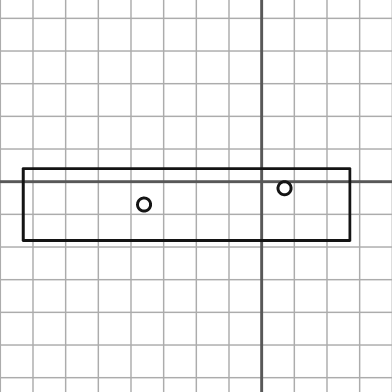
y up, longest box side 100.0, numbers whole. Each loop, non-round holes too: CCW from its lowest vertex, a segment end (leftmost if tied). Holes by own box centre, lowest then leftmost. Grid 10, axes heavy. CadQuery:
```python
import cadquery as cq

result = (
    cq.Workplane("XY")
    .moveTo(-73.0, -18.0)
    .lineTo(27.0, -18.0)
    .lineTo(27.0, 4.0)
    .lineTo(-73.0, 4.0)
    .close()
    .moveTo(-36.0, -7.0)
    .circle(2.0)
    .moveTo(7.0, -2.0)
    .circle(2.0)
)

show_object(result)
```